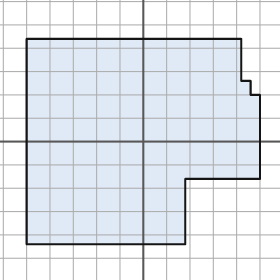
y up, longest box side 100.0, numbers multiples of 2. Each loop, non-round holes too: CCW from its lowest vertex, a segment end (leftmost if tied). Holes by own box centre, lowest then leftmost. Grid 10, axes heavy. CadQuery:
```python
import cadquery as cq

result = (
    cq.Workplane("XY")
    .moveTo(-50.0, -44.0)
    .lineTo(18.0, -44.0)
    .lineTo(18.0, -16.0)
    .lineTo(50.0, -16.0)
    .lineTo(50.0, 20.0)
    .lineTo(46.0, 20.0)
    .lineTo(46.0, 26.0)
    .lineTo(42.0, 26.0)
    .lineTo(42.0, 44.0)
    .lineTo(-50.0, 44.0)
    .close()
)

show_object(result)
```